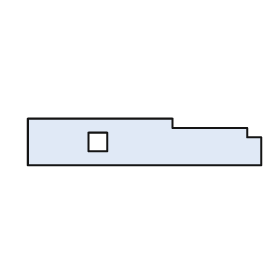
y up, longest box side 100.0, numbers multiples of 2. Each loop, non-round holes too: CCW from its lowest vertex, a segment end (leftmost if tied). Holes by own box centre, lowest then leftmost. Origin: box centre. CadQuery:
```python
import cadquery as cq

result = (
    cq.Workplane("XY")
    .moveTo(-50.0, -10.0)
    .lineTo(50.0, -10.0)
    .lineTo(50.0, 2.0)
    .lineTo(44.0, 2.0)
    .lineTo(44.0, 6.0)
    .lineTo(12.0, 6.0)
    .lineTo(12.0, 10.0)
    .lineTo(-50.0, 10.0)
    .close()
    .moveTo(-24.0, -4.0)
    .lineTo(-16.0, -4.0)
    .lineTo(-16.0, 4.0)
    .lineTo(-24.0, 4.0)
    .close()
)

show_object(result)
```